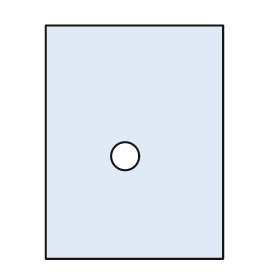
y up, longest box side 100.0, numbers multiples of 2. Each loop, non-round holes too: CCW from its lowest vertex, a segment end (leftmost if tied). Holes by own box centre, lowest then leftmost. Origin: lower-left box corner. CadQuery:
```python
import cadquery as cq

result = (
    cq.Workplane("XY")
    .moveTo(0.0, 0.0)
    .lineTo(76.0, 0.0)
    .lineTo(76.0, 100.0)
    .lineTo(0.0, 100.0)
    .close()
    .moveTo(34.0, 44.0)
    .circle(6.0)
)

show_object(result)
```